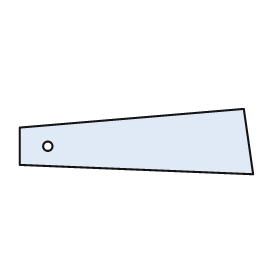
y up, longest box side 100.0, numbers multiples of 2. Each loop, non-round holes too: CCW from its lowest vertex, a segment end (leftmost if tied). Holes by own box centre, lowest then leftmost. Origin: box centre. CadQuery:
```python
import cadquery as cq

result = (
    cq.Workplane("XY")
    .moveTo(50.0, -14.0)
    .lineTo(46.0, 14.0)
    .lineTo(-50.0, 6.0)
    .lineTo(-50.0, -10.0)
    .close()
    .moveTo(-38.0, -2.0)
    .circle(2.0)
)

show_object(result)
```